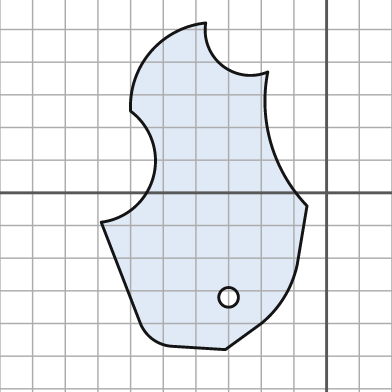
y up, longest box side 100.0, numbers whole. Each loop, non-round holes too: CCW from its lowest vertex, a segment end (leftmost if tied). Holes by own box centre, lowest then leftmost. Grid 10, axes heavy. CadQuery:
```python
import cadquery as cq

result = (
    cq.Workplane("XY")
    .moveTo(-31.0, -48.0)
    .lineTo(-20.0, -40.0)
    .threePointArc((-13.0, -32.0), (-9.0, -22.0))
    .lineTo(-6.0, -4.0)
    .threePointArc((-17.0, 15.0), (-18.0, 37.0))
    .threePointArc((-32.0, 39.0), (-37.0, 52.0))
    .threePointArc((-54.0, 43.0), (-60.0, 25.0))
    .threePointArc((-53.0, 5.0), (-69.0, -9.0))
    .lineTo(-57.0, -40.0)
    .threePointArc((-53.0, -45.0), (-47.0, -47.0))
    .close()
    .moveTo(-30.0, -32.0)
    .circle(3.0)
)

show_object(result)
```